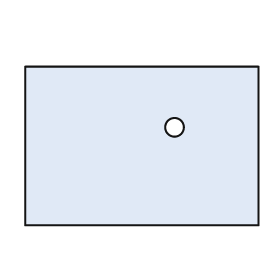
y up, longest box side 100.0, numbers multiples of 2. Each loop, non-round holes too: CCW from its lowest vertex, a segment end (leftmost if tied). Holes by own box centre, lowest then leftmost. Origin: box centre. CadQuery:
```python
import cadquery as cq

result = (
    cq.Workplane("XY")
    .moveTo(-50.0, -34.0)
    .lineTo(50.0, -34.0)
    .lineTo(50.0, 34.0)
    .lineTo(-50.0, 34.0)
    .close()
    .moveTo(14.0, 8.0)
    .circle(4.0)
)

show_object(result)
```